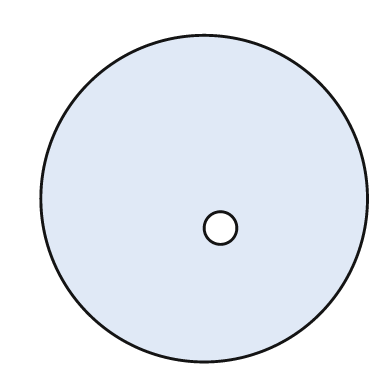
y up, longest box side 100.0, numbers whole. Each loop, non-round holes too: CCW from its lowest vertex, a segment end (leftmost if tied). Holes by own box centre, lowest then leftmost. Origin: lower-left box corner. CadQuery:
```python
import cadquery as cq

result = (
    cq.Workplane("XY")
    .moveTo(50.0, 50.0)
    .circle(50.0)
    .moveTo(55.0, 41.0)
    .circle(5.0)
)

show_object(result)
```